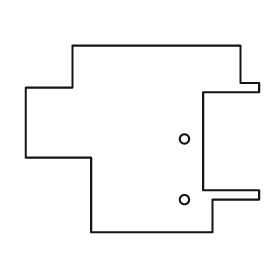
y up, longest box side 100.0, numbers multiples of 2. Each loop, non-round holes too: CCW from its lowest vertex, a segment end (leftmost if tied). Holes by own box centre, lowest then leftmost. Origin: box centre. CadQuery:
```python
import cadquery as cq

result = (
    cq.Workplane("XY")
    .moveTo(-22.0, -40.0)
    .lineTo(30.0, -40.0)
    .lineTo(30.0, -26.0)
    .lineTo(50.0, -26.0)
    .lineTo(50.0, -22.0)
    .lineTo(26.0, -22.0)
    .lineTo(26.0, 20.0)
    .lineTo(50.0, 20.0)
    .lineTo(50.0, 24.0)
    .lineTo(42.0, 24.0)
    .lineTo(42.0, 40.0)
    .lineTo(-30.0, 40.0)
    .lineTo(-30.0, 22.0)
    .lineTo(-50.0, 22.0)
    .lineTo(-50.0, -8.0)
    .lineTo(-22.0, -8.0)
    .close()
    .moveTo(18.0, -26.0)
    .circle(2.0)
    .moveTo(18.0, 0.0)
    .circle(2.0)
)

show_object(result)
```